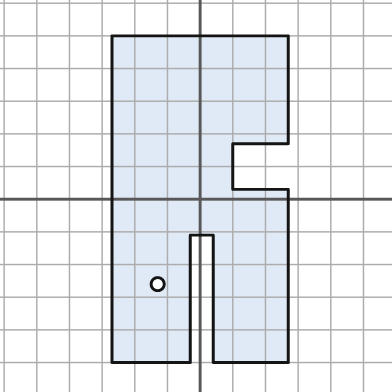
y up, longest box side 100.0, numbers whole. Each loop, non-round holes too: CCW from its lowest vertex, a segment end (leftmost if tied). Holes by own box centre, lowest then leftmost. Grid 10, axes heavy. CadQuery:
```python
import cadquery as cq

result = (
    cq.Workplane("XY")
    .moveTo(-27.0, -50.0)
    .lineTo(-3.0, -50.0)
    .lineTo(-3.0, -11.0)
    .lineTo(4.0, -11.0)
    .lineTo(4.0, -50.0)
    .lineTo(27.0, -50.0)
    .lineTo(27.0, 3.0)
    .lineTo(10.0, 3.0)
    .lineTo(10.0, 17.0)
    .lineTo(27.0, 17.0)
    .lineTo(27.0, 50.0)
    .lineTo(-27.0, 50.0)
    .close()
    .moveTo(-13.0, -26.0)
    .circle(2.0)
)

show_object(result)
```